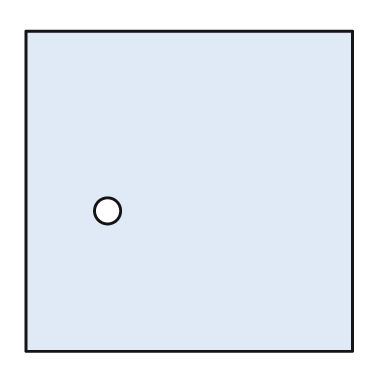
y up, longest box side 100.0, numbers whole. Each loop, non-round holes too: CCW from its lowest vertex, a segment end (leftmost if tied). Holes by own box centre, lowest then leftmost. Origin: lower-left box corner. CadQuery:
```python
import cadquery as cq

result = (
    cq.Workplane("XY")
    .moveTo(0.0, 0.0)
    .lineTo(100.0, 0.0)
    .lineTo(100.0, 98.0)
    .lineTo(0.0, 98.0)
    .close()
    .moveTo(25.0, 43.0)
    .circle(4.0)
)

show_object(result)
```